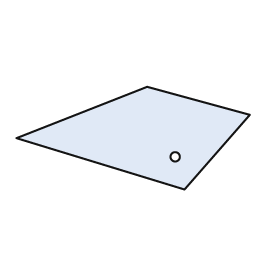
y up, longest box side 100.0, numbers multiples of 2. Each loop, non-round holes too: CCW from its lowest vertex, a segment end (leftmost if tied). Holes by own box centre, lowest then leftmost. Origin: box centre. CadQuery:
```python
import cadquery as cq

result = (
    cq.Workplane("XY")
    .moveTo(22.0, -22.0)
    .lineTo(50.0, 10.0)
    .lineTo(6.0, 22.0)
    .lineTo(-50.0, 0.0)
    .close()
    .moveTo(18.0, -8.0)
    .circle(2.0)
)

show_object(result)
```